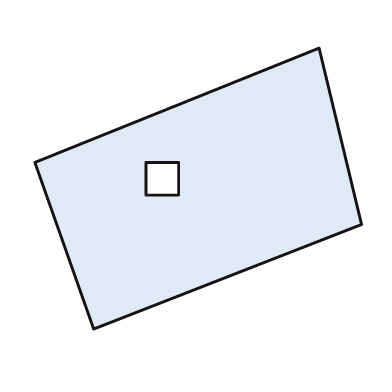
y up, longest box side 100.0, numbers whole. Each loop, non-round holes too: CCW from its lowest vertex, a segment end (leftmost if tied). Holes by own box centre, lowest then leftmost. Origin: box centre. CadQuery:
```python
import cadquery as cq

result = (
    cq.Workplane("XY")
    .moveTo(-32.0, -43.0)
    .lineTo(50.0, -11.0)
    .lineTo(37.0, 43.0)
    .lineTo(-50.0, 8.0)
    .close()
    .moveTo(-16.0, -2.0)
    .lineTo(-6.0, -2.0)
    .lineTo(-6.0, 8.0)
    .lineTo(-16.0, 8.0)
    .close()
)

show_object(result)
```